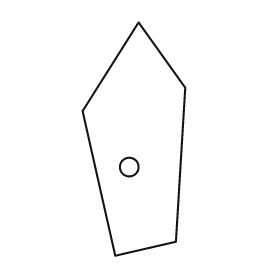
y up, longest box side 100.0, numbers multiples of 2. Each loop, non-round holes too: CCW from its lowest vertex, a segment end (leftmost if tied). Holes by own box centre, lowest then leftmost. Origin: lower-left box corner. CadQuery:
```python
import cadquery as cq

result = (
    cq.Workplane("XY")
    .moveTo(14.0, 0.0)
    .lineTo(40.0, 6.0)
    .lineTo(44.0, 72.0)
    .lineTo(24.0, 100.0)
    .lineTo(0.0, 62.0)
    .close()
    .moveTo(20.0, 38.0)
    .circle(4.0)
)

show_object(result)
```